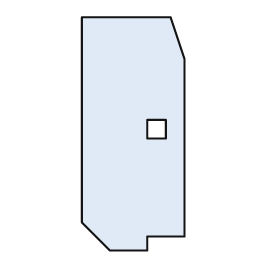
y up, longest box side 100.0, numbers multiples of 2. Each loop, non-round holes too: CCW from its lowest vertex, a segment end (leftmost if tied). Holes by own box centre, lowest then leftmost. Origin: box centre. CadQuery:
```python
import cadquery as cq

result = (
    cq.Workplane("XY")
    .moveTo(-10.0, -50.0)
    .lineTo(6.0, -50.0)
    .lineTo(6.0, -44.0)
    .lineTo(22.0, -44.0)
    .lineTo(22.0, 32.0)
    .lineTo(16.0, 50.0)
    .lineTo(-22.0, 50.0)
    .lineTo(-22.0, -38.0)
    .close()
    .moveTo(6.0, -2.0)
    .lineTo(14.0, -2.0)
    .lineTo(14.0, 6.0)
    .lineTo(6.0, 6.0)
    .close()
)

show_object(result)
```